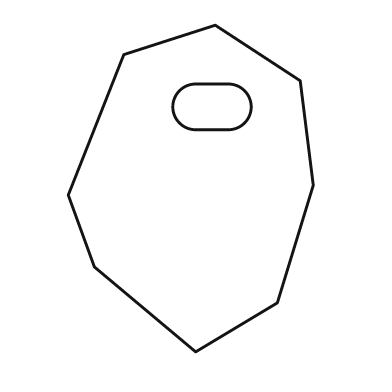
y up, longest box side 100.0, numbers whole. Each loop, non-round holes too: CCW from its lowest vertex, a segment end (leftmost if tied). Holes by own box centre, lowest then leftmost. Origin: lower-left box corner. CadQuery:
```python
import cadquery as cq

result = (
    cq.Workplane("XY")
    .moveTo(39.0, 0.0)
    .lineTo(64.0, 15.0)
    .lineTo(75.0, 51.0)
    .lineTo(71.0, 83.0)
    .lineTo(45.0, 100.0)
    .lineTo(17.0, 91.0)
    .lineTo(0.0, 48.0)
    .lineTo(8.0, 26.0)
    .close()
    .moveTo(39.0, 68.0)
    .lineTo(49.0, 68.0)
    .threePointArc((56.0, 75.0), (49.0, 82.0))
    .lineTo(39.0, 82.0)
    .threePointArc((32.0, 75.0), (39.0, 68.0))
    .close()
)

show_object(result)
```